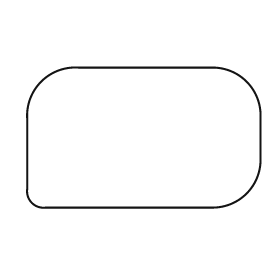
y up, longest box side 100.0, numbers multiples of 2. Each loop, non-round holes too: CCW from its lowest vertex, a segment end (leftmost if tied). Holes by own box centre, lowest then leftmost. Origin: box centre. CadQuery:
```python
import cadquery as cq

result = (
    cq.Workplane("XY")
    .moveTo(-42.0, -30.0)
    .lineTo(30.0, -30.0)
    .threePointArc((44.0, -24.0), (50.0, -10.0))
    .lineTo(50.0, 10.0)
    .threePointArc((44.0, 24.0), (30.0, 30.0))
    .lineTo(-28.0, 30.0)
    .threePointArc((-44.0, 24.0), (-50.0, 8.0))
    .lineTo(-50.0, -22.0)
    .threePointArc((-48.0, -28.0), (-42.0, -30.0))
    .close()
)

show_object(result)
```